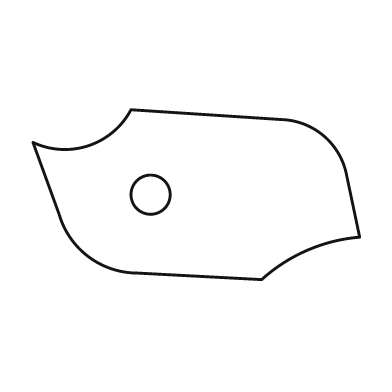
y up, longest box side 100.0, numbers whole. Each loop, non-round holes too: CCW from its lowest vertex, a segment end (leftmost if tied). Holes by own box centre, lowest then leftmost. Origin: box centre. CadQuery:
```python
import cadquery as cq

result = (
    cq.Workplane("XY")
    .moveTo(20.0, -26.0)
    .threePointArc((34.0, -17.0), (50.0, -13.0))
    .lineTo(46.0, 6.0)
    .threePointArc((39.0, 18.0), (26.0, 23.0))
    .lineTo(-20.0, 26.0)
    .threePointArc((-33.0, 15.0), (-50.0, 16.0))
    .lineTo(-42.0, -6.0)
    .threePointArc((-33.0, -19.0), (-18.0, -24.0))
    .close()
    .moveTo(-14.0, 0.0)
    .circle(6.0)
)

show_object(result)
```